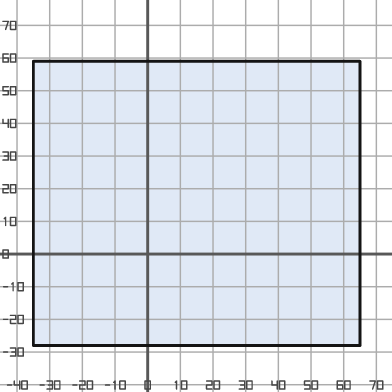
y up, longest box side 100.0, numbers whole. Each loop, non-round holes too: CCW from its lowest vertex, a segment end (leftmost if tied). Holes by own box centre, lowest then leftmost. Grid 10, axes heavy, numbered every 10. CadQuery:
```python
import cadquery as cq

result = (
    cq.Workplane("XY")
    .moveTo(-35.0, -28.0)
    .lineTo(65.0, -28.0)
    .lineTo(65.0, 59.0)
    .lineTo(-35.0, 59.0)
    .close()
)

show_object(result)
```